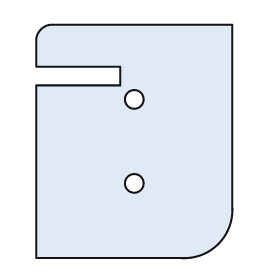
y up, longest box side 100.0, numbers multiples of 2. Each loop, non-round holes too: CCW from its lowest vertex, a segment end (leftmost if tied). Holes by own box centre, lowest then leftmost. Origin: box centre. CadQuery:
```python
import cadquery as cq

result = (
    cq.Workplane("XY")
    .moveTo(-42.0, -50.0)
    .lineTo(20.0, -50.0)
    .threePointArc((36.0, -44.0), (42.0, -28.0))
    .lineTo(42.0, 50.0)
    .lineTo(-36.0, 50.0)
    .threePointArc((-40.0, 48.0), (-42.0, 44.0))
    .lineTo(-42.0, 32.0)
    .lineTo(-6.0, 32.0)
    .lineTo(-6.0, 24.0)
    .lineTo(-42.0, 24.0)
    .close()
    .moveTo(0.0, -18.0)
    .circle(4.0)
    .moveTo(0.0, 18.0)
    .circle(4.0)
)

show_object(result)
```